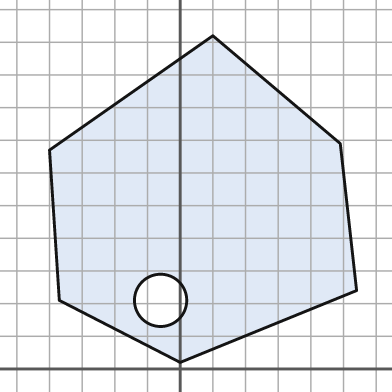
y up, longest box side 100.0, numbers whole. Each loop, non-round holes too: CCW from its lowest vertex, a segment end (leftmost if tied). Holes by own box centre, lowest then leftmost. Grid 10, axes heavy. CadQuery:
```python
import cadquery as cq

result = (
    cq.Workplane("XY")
    .moveTo(0.0, 2.0)
    .lineTo(54.0, 24.0)
    .lineTo(49.0, 69.0)
    .lineTo(10.0, 102.0)
    .lineTo(-40.0, 67.0)
    .lineTo(-37.0, 21.0)
    .close()
    .moveTo(-6.0, 21.0)
    .circle(8.0)
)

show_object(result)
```